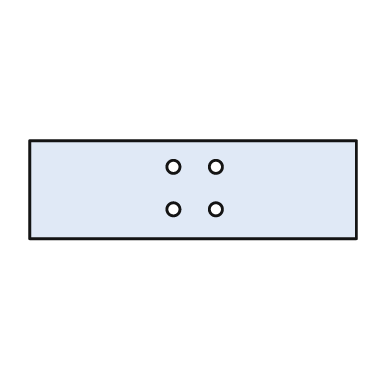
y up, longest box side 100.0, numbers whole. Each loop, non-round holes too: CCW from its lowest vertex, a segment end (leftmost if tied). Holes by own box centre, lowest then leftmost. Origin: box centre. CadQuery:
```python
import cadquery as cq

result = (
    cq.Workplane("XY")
    .moveTo(-50.0, -15.0)
    .lineTo(50.0, -15.0)
    .lineTo(50.0, 15.0)
    .lineTo(-50.0, 15.0)
    .close()
    .moveTo(-6.0, -6.0)
    .circle(2.0)
    .moveTo(7.0, -6.0)
    .circle(2.0)
    .moveTo(-6.0, 7.0)
    .circle(2.0)
    .moveTo(7.0, 7.0)
    .circle(2.0)
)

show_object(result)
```